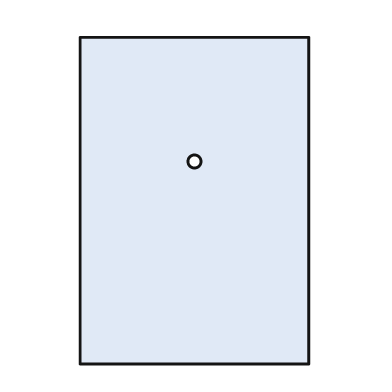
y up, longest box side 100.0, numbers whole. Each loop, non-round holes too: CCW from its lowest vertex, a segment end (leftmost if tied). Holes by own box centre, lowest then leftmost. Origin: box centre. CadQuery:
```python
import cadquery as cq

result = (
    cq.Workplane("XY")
    .moveTo(-35.0, -50.0)
    .lineTo(35.0, -50.0)
    .lineTo(35.0, 50.0)
    .lineTo(-35.0, 50.0)
    .close()
    .moveTo(0.0, 12.0)
    .circle(2.0)
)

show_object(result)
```